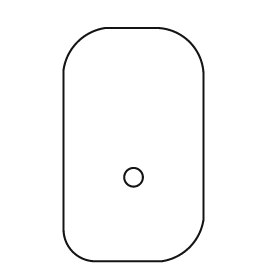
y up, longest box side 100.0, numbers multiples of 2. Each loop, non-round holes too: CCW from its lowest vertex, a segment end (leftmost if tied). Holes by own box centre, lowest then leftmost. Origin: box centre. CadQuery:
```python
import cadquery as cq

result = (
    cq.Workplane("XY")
    .moveTo(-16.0, -50.0)
    .lineTo(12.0, -50.0)
    .threePointArc((24.0, -44.0), (30.0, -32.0))
    .lineTo(30.0, 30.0)
    .threePointArc((24.0, 44.0), (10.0, 50.0))
    .lineTo(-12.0, 50.0)
    .threePointArc((-24.0, 44.0), (-30.0, 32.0))
    .lineTo(-30.0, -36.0)
    .threePointArc((-26.0, -46.0), (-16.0, -50.0))
    .close()
    .moveTo(0.0, -14.0)
    .circle(4.0)
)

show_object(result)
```